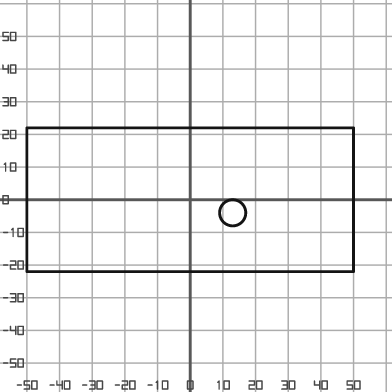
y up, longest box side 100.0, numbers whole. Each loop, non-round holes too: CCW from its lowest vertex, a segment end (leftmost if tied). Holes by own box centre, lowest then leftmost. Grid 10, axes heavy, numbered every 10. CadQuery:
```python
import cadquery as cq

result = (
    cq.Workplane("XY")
    .moveTo(-50.0, -22.0)
    .lineTo(50.0, -22.0)
    .lineTo(50.0, 22.0)
    .lineTo(-50.0, 22.0)
    .close()
    .moveTo(13.0, -4.0)
    .circle(4.0)
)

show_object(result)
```